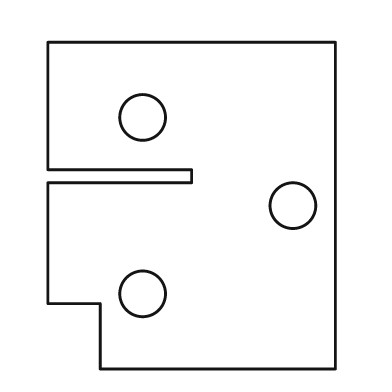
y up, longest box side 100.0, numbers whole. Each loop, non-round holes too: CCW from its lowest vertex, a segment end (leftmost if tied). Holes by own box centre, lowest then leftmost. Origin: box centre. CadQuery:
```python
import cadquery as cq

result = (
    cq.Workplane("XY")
    .moveTo(-28.0, -50.0)
    .lineTo(44.0, -50.0)
    .lineTo(44.0, 50.0)
    .lineTo(-44.0, 50.0)
    .lineTo(-44.0, 11.0)
    .lineTo(0.0, 11.0)
    .lineTo(0.0, 7.0)
    .lineTo(-44.0, 7.0)
    .lineTo(-44.0, -30.0)
    .lineTo(-28.0, -30.0)
    .close()
    .moveTo(-15.0, -27.0)
    .circle(7.0)
    .moveTo(31.0, 0.0)
    .circle(7.0)
    .moveTo(-15.0, 27.0)
    .circle(7.0)
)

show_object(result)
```